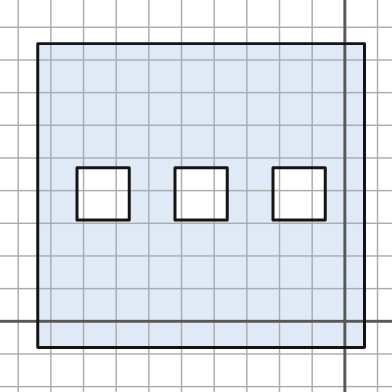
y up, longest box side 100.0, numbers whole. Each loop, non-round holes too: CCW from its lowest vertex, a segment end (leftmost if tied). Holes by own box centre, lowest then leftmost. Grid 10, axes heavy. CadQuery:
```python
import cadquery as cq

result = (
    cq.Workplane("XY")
    .moveTo(-94.0, -8.0)
    .lineTo(6.0, -8.0)
    .lineTo(6.0, 85.0)
    .lineTo(-94.0, 85.0)
    .close()
    .moveTo(-82.0, 31.0)
    .lineTo(-66.0, 31.0)
    .lineTo(-66.0, 47.0)
    .lineTo(-82.0, 47.0)
    .close()
    .moveTo(-52.0, 31.0)
    .lineTo(-36.0, 31.0)
    .lineTo(-36.0, 47.0)
    .lineTo(-52.0, 47.0)
    .close()
    .moveTo(-22.0, 31.0)
    .lineTo(-6.0, 31.0)
    .lineTo(-6.0, 47.0)
    .lineTo(-22.0, 47.0)
    .close()
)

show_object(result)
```